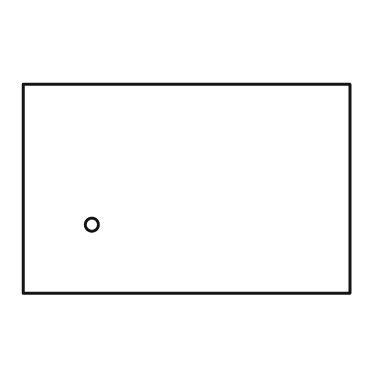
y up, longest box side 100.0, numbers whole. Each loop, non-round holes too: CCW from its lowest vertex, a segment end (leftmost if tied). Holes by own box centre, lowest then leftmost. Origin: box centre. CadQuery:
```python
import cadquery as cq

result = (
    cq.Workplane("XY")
    .moveTo(-50.0, -32.0)
    .lineTo(50.0, -32.0)
    .lineTo(50.0, 32.0)
    .lineTo(-50.0, 32.0)
    .close()
    .moveTo(-29.0, -11.0)
    .circle(2.0)
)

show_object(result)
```